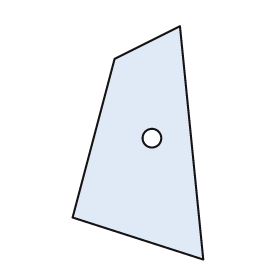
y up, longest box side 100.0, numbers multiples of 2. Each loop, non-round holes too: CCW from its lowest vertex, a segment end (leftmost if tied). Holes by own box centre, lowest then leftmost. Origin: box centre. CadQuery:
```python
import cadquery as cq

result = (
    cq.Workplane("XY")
    .moveTo(28.0, -50.0)
    .lineTo(18.0, 50.0)
    .lineTo(-10.0, 36.0)
    .lineTo(-28.0, -32.0)
    .close()
    .moveTo(6.0, 2.0)
    .circle(4.0)
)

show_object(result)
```